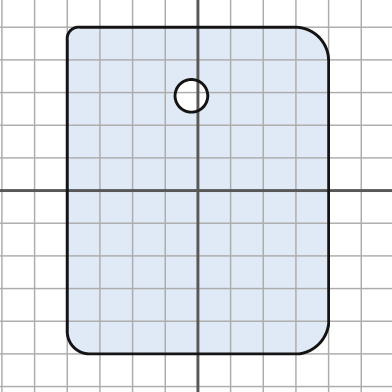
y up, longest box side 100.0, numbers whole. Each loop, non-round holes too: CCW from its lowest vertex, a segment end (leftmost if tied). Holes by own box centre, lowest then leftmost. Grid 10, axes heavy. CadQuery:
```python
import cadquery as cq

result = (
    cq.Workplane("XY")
    .moveTo(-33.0, -50.0)
    .lineTo(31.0, -50.0)
    .threePointArc((37.0, -47.0), (40.0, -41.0))
    .lineTo(40.0, 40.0)
    .threePointArc((37.0, 47.0), (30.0, 50.0))
    .lineTo(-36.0, 50.0)
    .threePointArc((-39.0, 49.0), (-40.0, 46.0))
    .lineTo(-40.0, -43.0)
    .threePointArc((-38.0, -48.0), (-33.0, -50.0))
    .close()
    .moveTo(-2.0, 29.0)
    .circle(5.0)
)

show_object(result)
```